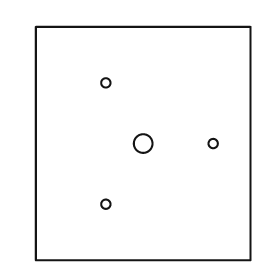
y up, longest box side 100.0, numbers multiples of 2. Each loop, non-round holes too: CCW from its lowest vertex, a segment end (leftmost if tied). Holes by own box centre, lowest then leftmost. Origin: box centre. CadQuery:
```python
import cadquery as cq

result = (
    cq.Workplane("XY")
    .moveTo(-46.0, -50.0)
    .lineTo(46.0, -50.0)
    .lineTo(46.0, 50.0)
    .lineTo(-46.0, 50.0)
    .close()
    .moveTo(-16.0, -26.0)
    .circle(2.0)
    .moveTo(0.0, 0.0)
    .circle(4.0)
    .moveTo(30.0, 0.0)
    .circle(2.0)
    .moveTo(-16.0, 26.0)
    .circle(2.0)
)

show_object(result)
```